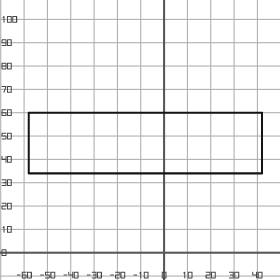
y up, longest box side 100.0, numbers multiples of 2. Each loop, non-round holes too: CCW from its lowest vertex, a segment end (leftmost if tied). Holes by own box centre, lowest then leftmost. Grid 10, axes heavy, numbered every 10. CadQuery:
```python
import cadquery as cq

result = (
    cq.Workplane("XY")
    .moveTo(-58.0, 34.0)
    .lineTo(42.0, 34.0)
    .lineTo(42.0, 60.0)
    .lineTo(-58.0, 60.0)
    .close()
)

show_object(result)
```